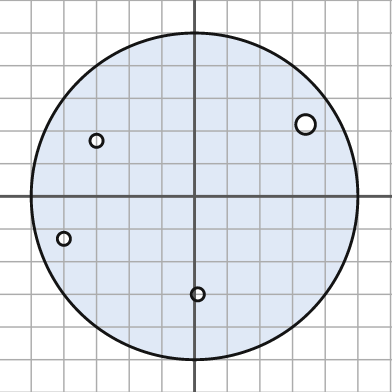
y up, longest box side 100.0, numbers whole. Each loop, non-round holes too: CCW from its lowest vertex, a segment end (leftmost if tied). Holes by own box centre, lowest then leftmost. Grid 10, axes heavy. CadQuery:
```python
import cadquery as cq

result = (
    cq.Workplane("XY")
    .moveTo(0.0, 0.0)
    .circle(50.0)
    .moveTo(1.0, -30.0)
    .circle(2.0)
    .moveTo(-40.0, -13.0)
    .circle(2.0)
    .moveTo(-30.0, 17.0)
    .circle(2.0)
    .moveTo(34.0, 22.0)
    .circle(3.0)
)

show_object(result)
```